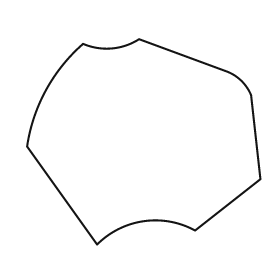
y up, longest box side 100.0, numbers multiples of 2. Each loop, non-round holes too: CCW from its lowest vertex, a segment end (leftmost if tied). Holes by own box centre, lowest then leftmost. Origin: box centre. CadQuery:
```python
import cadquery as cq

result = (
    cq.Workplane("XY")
    .moveTo(-20.0, -44.0)
    .threePointArc((0.0, -34.0), (22.0, -38.0))
    .lineTo(50.0, -16.0)
    .lineTo(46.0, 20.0)
    .threePointArc((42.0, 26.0), (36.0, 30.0))
    .lineTo(-2.0, 44.0)
    .threePointArc((-14.0, 40.0), (-26.0, 42.0))
    .threePointArc((-42.0, 22.0), (-50.0, -2.0))
    .close()
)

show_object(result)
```